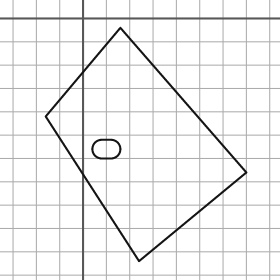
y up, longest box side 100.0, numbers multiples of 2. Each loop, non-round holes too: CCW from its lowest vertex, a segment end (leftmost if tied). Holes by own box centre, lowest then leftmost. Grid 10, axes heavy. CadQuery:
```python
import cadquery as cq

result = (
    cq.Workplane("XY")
    .moveTo(24.0, -104.0)
    .lineTo(70.0, -66.0)
    .lineTo(16.0, -4.0)
    .lineTo(-16.0, -42.0)
    .close()
    .moveTo(8.0, -60.0)
    .lineTo(12.0, -60.0)
    .threePointArc((16.0, -56.0), (12.0, -52.0))
    .lineTo(8.0, -52.0)
    .threePointArc((4.0, -56.0), (8.0, -60.0))
    .close()
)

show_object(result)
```